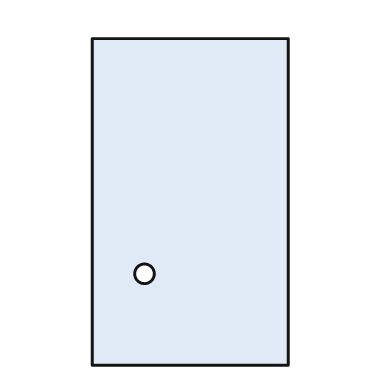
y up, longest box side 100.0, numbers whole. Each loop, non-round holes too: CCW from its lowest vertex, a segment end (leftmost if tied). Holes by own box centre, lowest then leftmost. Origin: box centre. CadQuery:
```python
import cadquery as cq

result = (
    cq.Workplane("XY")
    .moveTo(-30.0, -50.0)
    .lineTo(30.0, -50.0)
    .lineTo(30.0, 50.0)
    .lineTo(-30.0, 50.0)
    .close()
    .moveTo(-14.0, -22.0)
    .circle(3.0)
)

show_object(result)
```